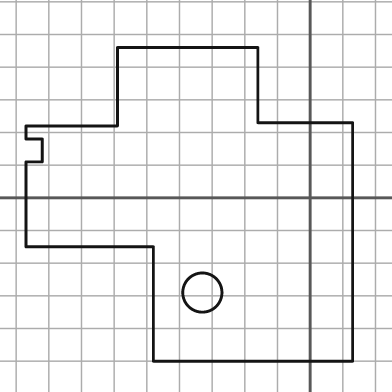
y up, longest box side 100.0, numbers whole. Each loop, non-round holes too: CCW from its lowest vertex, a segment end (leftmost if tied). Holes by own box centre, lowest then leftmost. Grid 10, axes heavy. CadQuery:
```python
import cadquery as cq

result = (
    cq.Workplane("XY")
    .moveTo(-48.0, -50.0)
    .lineTo(13.0, -50.0)
    .lineTo(13.0, 23.0)
    .lineTo(-16.0, 23.0)
    .lineTo(-16.0, 46.0)
    .lineTo(-59.0, 46.0)
    .lineTo(-59.0, 22.0)
    .lineTo(-87.0, 22.0)
    .lineTo(-87.0, 18.0)
    .lineTo(-82.0, 18.0)
    .lineTo(-82.0, 11.0)
    .lineTo(-87.0, 11.0)
    .lineTo(-87.0, -15.0)
    .lineTo(-48.0, -15.0)
    .close()
    .moveTo(-33.0, -29.0)
    .circle(6.0)
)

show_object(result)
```